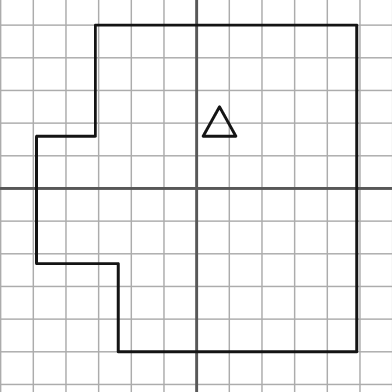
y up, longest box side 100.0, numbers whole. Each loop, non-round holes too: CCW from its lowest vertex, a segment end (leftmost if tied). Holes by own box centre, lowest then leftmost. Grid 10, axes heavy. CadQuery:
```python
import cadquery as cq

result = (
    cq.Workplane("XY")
    .moveTo(-24.0, -50.0)
    .lineTo(49.0, -50.0)
    .lineTo(49.0, 50.0)
    .lineTo(-31.0, 50.0)
    .lineTo(-31.0, 16.0)
    .lineTo(-49.0, 16.0)
    .lineTo(-49.0, -23.0)
    .lineTo(-24.0, -23.0)
    .close()
    .moveTo(2.0, 16.0)
    .lineTo(12.0, 16.0)
    .lineTo(7.0, 25.0)
    .close()
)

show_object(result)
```